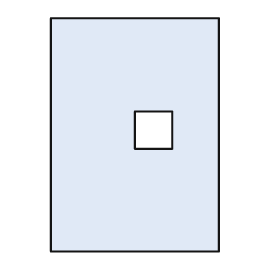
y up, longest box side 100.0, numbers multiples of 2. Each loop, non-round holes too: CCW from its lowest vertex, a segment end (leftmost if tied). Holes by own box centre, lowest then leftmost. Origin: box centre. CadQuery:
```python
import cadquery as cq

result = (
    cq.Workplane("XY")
    .moveTo(-36.0, -50.0)
    .lineTo(36.0, -50.0)
    .lineTo(36.0, 50.0)
    .lineTo(-36.0, 50.0)
    .close()
    .moveTo(0.0, -6.0)
    .lineTo(16.0, -6.0)
    .lineTo(16.0, 10.0)
    .lineTo(0.0, 10.0)
    .close()
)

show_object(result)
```